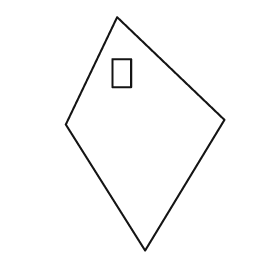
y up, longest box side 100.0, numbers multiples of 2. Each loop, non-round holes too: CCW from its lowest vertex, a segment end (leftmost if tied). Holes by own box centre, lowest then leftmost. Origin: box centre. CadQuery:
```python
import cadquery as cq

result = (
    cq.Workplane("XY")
    .moveTo(0.0, -50.0)
    .lineTo(34.0, 6.0)
    .lineTo(-12.0, 50.0)
    .lineTo(-34.0, 4.0)
    .close()
    .moveTo(-14.0, 20.0)
    .lineTo(-6.0, 20.0)
    .lineTo(-6.0, 32.0)
    .lineTo(-14.0, 32.0)
    .close()
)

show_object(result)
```